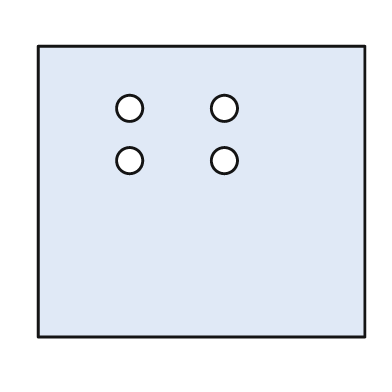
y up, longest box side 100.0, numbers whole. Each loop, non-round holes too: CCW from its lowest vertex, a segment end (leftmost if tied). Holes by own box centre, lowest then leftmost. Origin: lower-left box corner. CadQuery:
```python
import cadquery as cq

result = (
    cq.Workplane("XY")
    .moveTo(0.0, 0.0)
    .lineTo(100.0, 0.0)
    .lineTo(100.0, 89.0)
    .lineTo(0.0, 89.0)
    .close()
    .moveTo(28.0, 54.0)
    .circle(4.0)
    .moveTo(57.0, 54.0)
    .circle(4.0)
    .moveTo(28.0, 70.0)
    .circle(4.0)
    .moveTo(57.0, 70.0)
    .circle(4.0)
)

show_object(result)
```